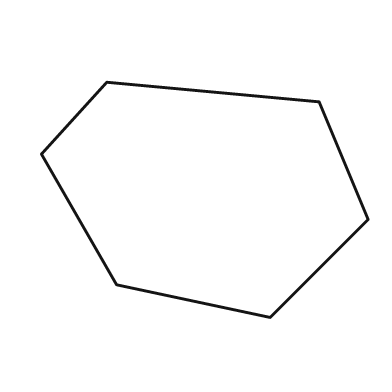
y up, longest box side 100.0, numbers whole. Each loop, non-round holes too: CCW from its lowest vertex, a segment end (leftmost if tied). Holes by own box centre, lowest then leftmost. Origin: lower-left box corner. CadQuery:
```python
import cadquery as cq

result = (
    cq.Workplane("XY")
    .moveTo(70.0, 0.0)
    .lineTo(100.0, 30.0)
    .lineTo(85.0, 66.0)
    .lineTo(20.0, 72.0)
    .lineTo(0.0, 50.0)
    .lineTo(23.0, 10.0)
    .close()
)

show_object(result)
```